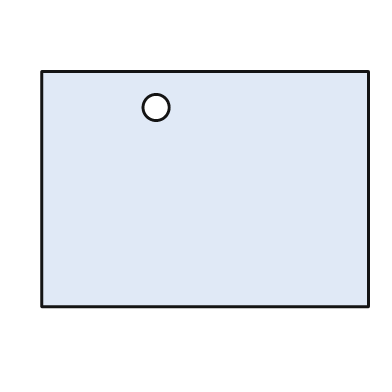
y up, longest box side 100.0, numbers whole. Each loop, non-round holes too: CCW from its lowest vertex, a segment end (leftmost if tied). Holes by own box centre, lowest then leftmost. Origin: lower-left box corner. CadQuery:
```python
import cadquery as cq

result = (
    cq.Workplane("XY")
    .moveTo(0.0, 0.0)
    .lineTo(100.0, 0.0)
    .lineTo(100.0, 72.0)
    .lineTo(0.0, 72.0)
    .close()
    .moveTo(35.0, 61.0)
    .circle(4.0)
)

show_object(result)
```